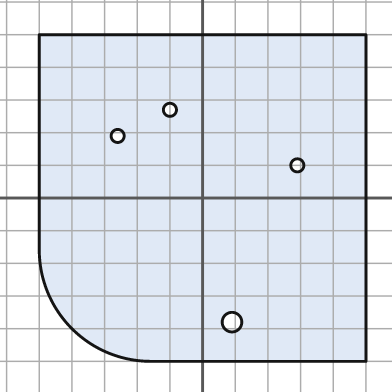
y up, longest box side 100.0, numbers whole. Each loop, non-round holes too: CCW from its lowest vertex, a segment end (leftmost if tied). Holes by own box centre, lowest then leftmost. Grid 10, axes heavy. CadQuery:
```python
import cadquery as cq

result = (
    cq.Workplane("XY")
    .moveTo(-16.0, -50.0)
    .lineTo(50.0, -50.0)
    .lineTo(50.0, 50.0)
    .lineTo(-50.0, 50.0)
    .lineTo(-50.0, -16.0)
    .threePointArc((-40.0, -40.0), (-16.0, -50.0))
    .close()
    .moveTo(9.0, -38.0)
    .circle(3.0)
    .moveTo(29.0, 10.0)
    .circle(2.0)
    .moveTo(-26.0, 19.0)
    .circle(2.0)
    .moveTo(-10.0, 27.0)
    .circle(2.0)
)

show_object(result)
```